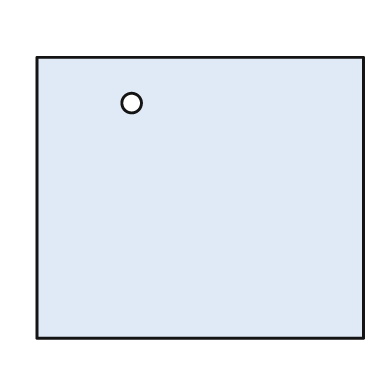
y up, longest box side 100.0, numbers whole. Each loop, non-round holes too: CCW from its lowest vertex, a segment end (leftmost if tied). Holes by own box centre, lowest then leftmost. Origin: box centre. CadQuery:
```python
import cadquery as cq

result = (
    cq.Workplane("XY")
    .moveTo(-50.0, -43.0)
    .lineTo(50.0, -43.0)
    .lineTo(50.0, 43.0)
    .lineTo(-50.0, 43.0)
    .close()
    .moveTo(-21.0, 29.0)
    .circle(3.0)
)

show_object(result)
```